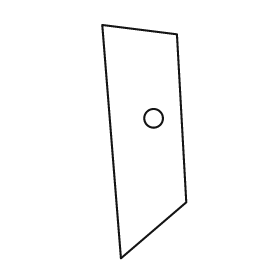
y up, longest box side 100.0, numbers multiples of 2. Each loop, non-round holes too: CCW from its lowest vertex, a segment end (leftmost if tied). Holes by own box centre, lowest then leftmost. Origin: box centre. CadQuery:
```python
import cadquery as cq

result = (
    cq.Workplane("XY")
    .moveTo(-10.0, -50.0)
    .lineTo(18.0, -26.0)
    .lineTo(14.0, 46.0)
    .lineTo(-18.0, 50.0)
    .close()
    .moveTo(4.0, 10.0)
    .circle(4.0)
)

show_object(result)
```